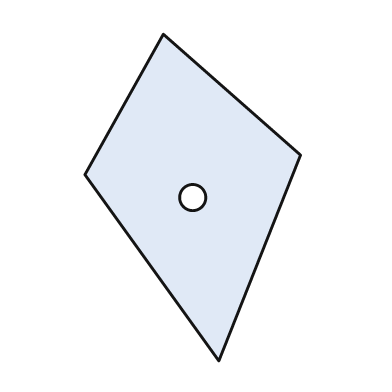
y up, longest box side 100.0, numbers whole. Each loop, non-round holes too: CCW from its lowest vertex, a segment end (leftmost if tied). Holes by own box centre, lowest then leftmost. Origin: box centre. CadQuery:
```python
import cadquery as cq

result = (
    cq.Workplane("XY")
    .moveTo(8.0, -50.0)
    .lineTo(33.0, 13.0)
    .lineTo(-9.0, 50.0)
    .lineTo(-33.0, 7.0)
    .close()
    .moveTo(0.0, 0.0)
    .circle(4.0)
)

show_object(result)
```